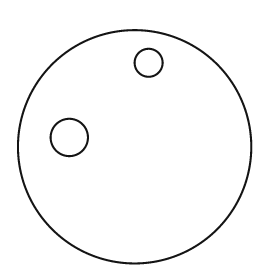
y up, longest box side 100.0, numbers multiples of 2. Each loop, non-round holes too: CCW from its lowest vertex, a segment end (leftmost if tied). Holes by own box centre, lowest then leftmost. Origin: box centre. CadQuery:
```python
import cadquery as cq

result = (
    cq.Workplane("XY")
    .moveTo(0.0, 0.0)
    .circle(50.0)
    .moveTo(-28.0, 4.0)
    .circle(8.0)
    .moveTo(6.0, 36.0)
    .circle(6.0)
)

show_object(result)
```